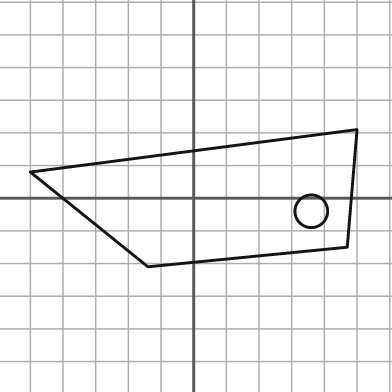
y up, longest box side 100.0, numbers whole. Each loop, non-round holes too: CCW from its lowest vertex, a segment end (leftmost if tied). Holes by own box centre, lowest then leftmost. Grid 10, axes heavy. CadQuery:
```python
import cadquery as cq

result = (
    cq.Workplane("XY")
    .moveTo(-14.0, -21.0)
    .lineTo(47.0, -15.0)
    .lineTo(50.0, 21.0)
    .lineTo(-50.0, 8.0)
    .close()
    .moveTo(36.0, -4.0)
    .circle(5.0)
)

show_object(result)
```